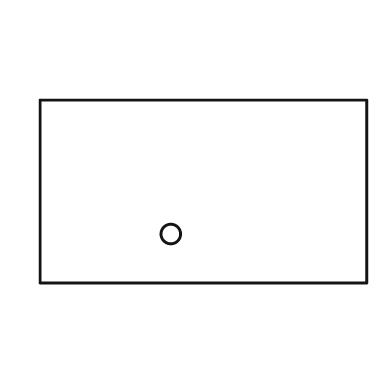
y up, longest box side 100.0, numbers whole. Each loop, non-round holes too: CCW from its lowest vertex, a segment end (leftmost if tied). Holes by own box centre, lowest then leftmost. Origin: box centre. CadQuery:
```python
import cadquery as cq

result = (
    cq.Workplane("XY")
    .moveTo(-50.0, -28.0)
    .lineTo(50.0, -28.0)
    .lineTo(50.0, 28.0)
    .lineTo(-50.0, 28.0)
    .close()
    .moveTo(-10.0, -13.0)
    .circle(3.0)
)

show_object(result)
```